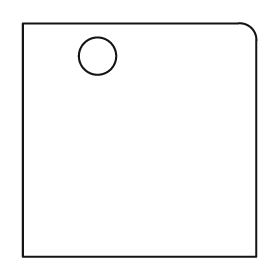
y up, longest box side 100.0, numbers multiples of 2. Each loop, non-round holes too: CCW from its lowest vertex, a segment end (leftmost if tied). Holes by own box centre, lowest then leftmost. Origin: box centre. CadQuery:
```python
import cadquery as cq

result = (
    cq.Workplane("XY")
    .moveTo(-50.0, -50.0)
    .lineTo(50.0, -50.0)
    .lineTo(50.0, 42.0)
    .threePointArc((48.0, 48.0), (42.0, 50.0))
    .lineTo(-50.0, 50.0)
    .close()
    .moveTo(-18.0, 36.0)
    .circle(8.0)
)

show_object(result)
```